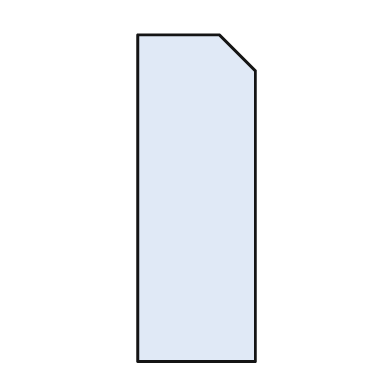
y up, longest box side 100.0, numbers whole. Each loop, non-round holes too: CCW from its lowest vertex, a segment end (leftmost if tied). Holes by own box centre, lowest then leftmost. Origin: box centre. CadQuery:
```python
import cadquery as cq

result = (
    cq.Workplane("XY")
    .moveTo(-18.0, -50.0)
    .lineTo(18.0, -50.0)
    .lineTo(18.0, 39.0)
    .lineTo(7.0, 50.0)
    .lineTo(-18.0, 50.0)
    .close()
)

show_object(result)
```